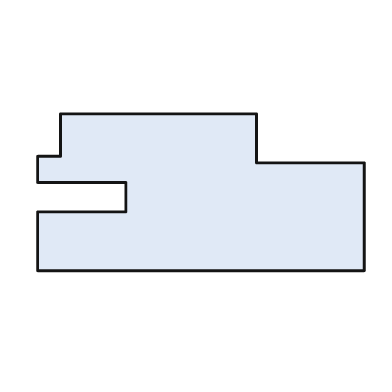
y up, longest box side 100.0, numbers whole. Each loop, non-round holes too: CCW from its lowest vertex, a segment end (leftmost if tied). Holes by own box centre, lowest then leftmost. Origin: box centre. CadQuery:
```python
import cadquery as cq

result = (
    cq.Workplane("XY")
    .moveTo(-50.0, -24.0)
    .lineTo(50.0, -24.0)
    .lineTo(50.0, 9.0)
    .lineTo(17.0, 9.0)
    .lineTo(17.0, 24.0)
    .lineTo(-43.0, 24.0)
    .lineTo(-43.0, 11.0)
    .lineTo(-50.0, 11.0)
    .lineTo(-50.0, 3.0)
    .lineTo(-23.0, 3.0)
    .lineTo(-23.0, -6.0)
    .lineTo(-50.0, -6.0)
    .close()
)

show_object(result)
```